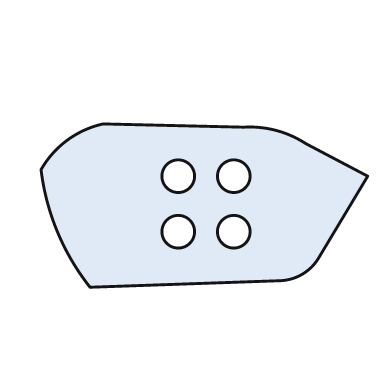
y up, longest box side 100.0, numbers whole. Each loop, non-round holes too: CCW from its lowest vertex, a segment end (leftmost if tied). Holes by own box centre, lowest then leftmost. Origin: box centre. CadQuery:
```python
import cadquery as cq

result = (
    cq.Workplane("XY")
    .moveTo(-35.0, -25.0)
    .lineTo(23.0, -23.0)
    .threePointArc((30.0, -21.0), (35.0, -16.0))
    .lineTo(50.0, 9.0)
    .lineTo(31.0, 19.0)
    .threePointArc((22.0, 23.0), (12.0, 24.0))
    .lineTo(-31.0, 25.0)
    .threePointArc((-42.0, 20.0), (-50.0, 11.0))
    .threePointArc((-45.0, -8.0), (-35.0, -25.0))
    .close()
    .moveTo(-8.0, -8.0)
    .circle(5.0)
    .moveTo(9.0, -8.0)
    .circle(5.0)
    .moveTo(-8.0, 9.0)
    .circle(5.0)
    .moveTo(9.0, 9.0)
    .circle(5.0)
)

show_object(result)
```